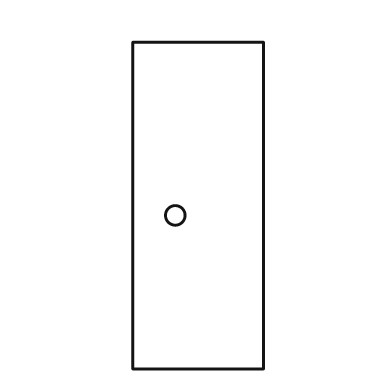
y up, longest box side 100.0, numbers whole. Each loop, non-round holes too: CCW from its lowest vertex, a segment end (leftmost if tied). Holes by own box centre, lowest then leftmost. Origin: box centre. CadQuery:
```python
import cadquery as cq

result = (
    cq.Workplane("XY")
    .moveTo(-20.0, -50.0)
    .lineTo(20.0, -50.0)
    .lineTo(20.0, 50.0)
    .lineTo(-20.0, 50.0)
    .close()
    .moveTo(-7.0, -3.0)
    .circle(3.0)
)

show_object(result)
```